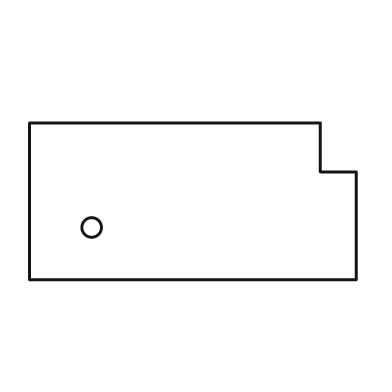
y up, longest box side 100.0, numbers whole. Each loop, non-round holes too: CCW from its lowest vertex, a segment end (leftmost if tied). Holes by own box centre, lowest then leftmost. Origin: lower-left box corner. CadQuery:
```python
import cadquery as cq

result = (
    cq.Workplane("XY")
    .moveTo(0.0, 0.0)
    .lineTo(100.0, 0.0)
    .lineTo(100.0, 33.0)
    .lineTo(89.0, 33.0)
    .lineTo(89.0, 48.0)
    .lineTo(0.0, 48.0)
    .close()
    .moveTo(19.0, 16.0)
    .circle(3.0)
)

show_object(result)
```